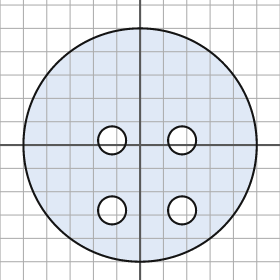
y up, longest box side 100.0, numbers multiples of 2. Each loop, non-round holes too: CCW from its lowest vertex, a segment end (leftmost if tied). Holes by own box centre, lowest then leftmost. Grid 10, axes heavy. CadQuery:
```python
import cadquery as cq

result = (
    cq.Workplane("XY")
    .moveTo(0.0, 0.0)
    .circle(50.0)
    .moveTo(-12.0, -28.0)
    .circle(6.0)
    .moveTo(18.0, -28.0)
    .circle(6.0)
    .moveTo(-12.0, 2.0)
    .circle(6.0)
    .moveTo(18.0, 2.0)
    .circle(6.0)
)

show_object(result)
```